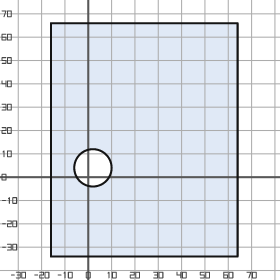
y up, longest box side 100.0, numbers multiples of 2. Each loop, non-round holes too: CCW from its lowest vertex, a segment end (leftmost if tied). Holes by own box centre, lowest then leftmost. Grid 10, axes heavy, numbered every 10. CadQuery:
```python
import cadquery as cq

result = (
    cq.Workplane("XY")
    .moveTo(-16.0, -34.0)
    .lineTo(64.0, -34.0)
    .lineTo(64.0, 66.0)
    .lineTo(-16.0, 66.0)
    .close()
    .moveTo(2.0, 4.0)
    .circle(8.0)
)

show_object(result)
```